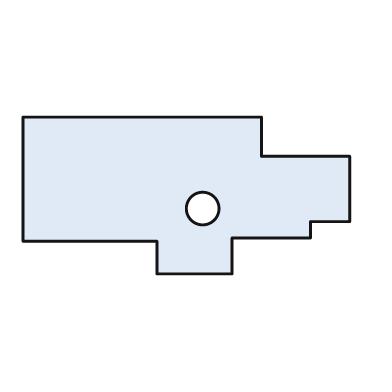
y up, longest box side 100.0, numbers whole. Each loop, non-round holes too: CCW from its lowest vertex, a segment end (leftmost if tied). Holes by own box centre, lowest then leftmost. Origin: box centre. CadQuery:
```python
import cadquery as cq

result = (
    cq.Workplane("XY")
    .moveTo(-9.0, -24.0)
    .lineTo(14.0, -24.0)
    .lineTo(14.0, -13.0)
    .lineTo(38.0, -13.0)
    .lineTo(38.0, -8.0)
    .lineTo(50.0, -8.0)
    .lineTo(50.0, 12.0)
    .lineTo(23.0, 12.0)
    .lineTo(23.0, 24.0)
    .lineTo(-50.0, 24.0)
    .lineTo(-50.0, -14.0)
    .lineTo(-9.0, -14.0)
    .close()
    .moveTo(5.0, -4.0)
    .circle(5.0)
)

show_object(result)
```